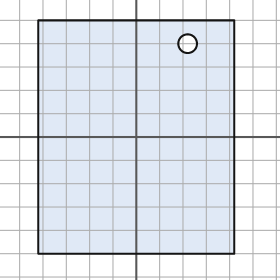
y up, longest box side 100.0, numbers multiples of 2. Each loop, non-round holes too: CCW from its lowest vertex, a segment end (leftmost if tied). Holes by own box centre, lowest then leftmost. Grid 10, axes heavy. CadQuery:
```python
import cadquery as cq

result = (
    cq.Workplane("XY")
    .moveTo(-42.0, -50.0)
    .lineTo(42.0, -50.0)
    .lineTo(42.0, 50.0)
    .lineTo(-42.0, 50.0)
    .close()
    .moveTo(22.0, 40.0)
    .circle(4.0)
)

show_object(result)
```